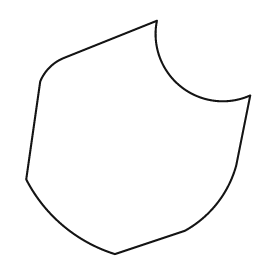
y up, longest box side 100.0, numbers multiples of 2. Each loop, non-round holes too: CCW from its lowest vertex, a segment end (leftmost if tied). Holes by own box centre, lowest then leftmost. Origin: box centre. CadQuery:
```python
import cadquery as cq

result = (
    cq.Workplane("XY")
    .moveTo(-10.0, -50.0)
    .lineTo(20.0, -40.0)
    .threePointArc((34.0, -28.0), (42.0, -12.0))
    .lineTo(48.0, 18.0)
    .threePointArc((18.0, 22.0), (8.0, 50.0))
    .lineTo(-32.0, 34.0)
    .threePointArc((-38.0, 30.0), (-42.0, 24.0))
    .lineTo(-48.0, -18.0)
    .threePointArc((-32.0, -38.0), (-10.0, -50.0))
    .close()
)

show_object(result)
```